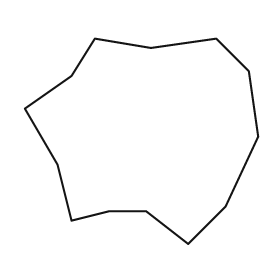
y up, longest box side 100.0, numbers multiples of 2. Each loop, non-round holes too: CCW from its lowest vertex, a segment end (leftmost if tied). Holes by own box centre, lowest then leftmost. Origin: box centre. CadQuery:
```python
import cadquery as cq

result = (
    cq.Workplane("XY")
    .moveTo(20.0, -44.0)
    .lineTo(36.0, -28.0)
    .lineTo(50.0, 2.0)
    .lineTo(46.0, 30.0)
    .lineTo(32.0, 44.0)
    .lineTo(4.0, 40.0)
    .lineTo(-20.0, 44.0)
    .lineTo(-30.0, 28.0)
    .lineTo(-50.0, 14.0)
    .lineTo(-36.0, -10.0)
    .lineTo(-30.0, -34.0)
    .lineTo(-14.0, -30.0)
    .lineTo(2.0, -30.0)
    .close()
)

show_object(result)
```